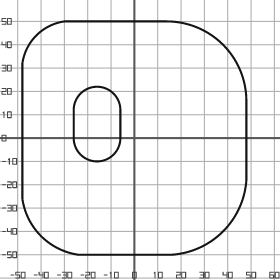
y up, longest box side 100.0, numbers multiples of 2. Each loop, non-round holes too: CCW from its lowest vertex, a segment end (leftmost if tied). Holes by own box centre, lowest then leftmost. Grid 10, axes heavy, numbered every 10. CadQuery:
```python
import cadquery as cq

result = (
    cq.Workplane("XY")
    .moveTo(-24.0, -50.0)
    .lineTo(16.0, -50.0)
    .threePointArc((38.0, -40.0), (48.0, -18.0))
    .lineTo(48.0, 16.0)
    .threePointArc((38.0, 40.0), (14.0, 50.0))
    .lineTo(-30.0, 50.0)
    .threePointArc((-42.0, 44.0), (-48.0, 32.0))
    .lineTo(-48.0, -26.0)
    .threePointArc((-40.0, -42.0), (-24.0, -50.0))
    .close()
    .moveTo(-26.0, 0.0)
    .threePointArc((-16.0, -10.0), (-6.0, 0.0))
    .lineTo(-6.0, 12.0)
    .threePointArc((-16.0, 22.0), (-26.0, 12.0))
    .close()
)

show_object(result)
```